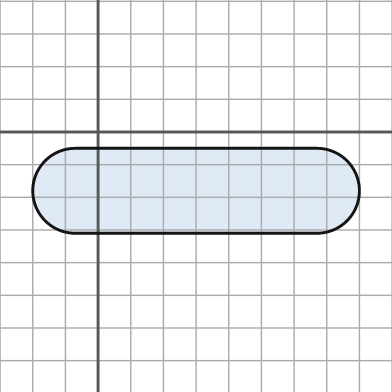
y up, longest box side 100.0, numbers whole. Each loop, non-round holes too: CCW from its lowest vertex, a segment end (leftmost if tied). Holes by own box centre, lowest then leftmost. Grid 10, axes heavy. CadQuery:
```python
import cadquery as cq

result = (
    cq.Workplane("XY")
    .moveTo(-7.0, -31.0)
    .lineTo(67.0, -31.0)
    .threePointArc((80.0, -18.0), (67.0, -5.0))
    .lineTo(-7.0, -5.0)
    .threePointArc((-20.0, -18.0), (-7.0, -31.0))
    .close()
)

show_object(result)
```